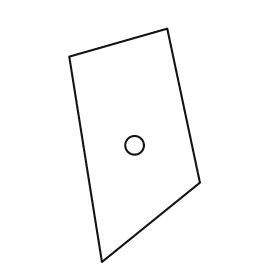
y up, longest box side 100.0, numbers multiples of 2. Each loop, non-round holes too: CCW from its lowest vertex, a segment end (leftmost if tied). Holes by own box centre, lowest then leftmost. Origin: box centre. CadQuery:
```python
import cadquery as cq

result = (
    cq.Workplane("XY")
    .moveTo(-14.0, -50.0)
    .lineTo(28.0, -16.0)
    .lineTo(14.0, 50.0)
    .lineTo(-28.0, 38.0)
    .close()
    .moveTo(0.0, 0.0)
    .circle(4.0)
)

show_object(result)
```